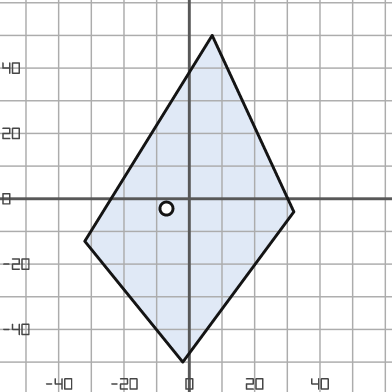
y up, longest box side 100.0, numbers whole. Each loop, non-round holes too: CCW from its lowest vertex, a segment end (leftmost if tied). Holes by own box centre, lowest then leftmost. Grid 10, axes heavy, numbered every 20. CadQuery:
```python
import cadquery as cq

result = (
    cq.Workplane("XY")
    .moveTo(-2.0, -50.0)
    .lineTo(32.0, -4.0)
    .lineTo(7.0, 50.0)
    .lineTo(-32.0, -13.0)
    .close()
    .moveTo(-7.0, -3.0)
    .circle(2.0)
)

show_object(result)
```